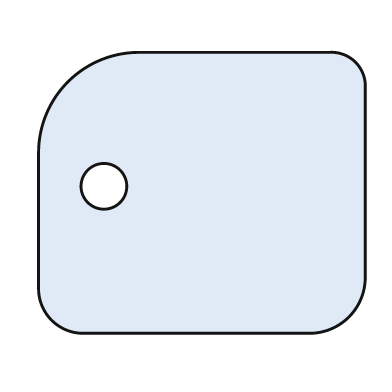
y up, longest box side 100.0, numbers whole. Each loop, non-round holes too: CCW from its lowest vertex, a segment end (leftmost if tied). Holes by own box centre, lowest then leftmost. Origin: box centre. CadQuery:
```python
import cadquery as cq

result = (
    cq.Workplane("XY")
    .moveTo(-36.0, -43.0)
    .lineTo(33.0, -43.0)
    .threePointArc((45.0, -38.0), (50.0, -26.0))
    .lineTo(50.0, 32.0)
    .threePointArc((47.0, 40.0), (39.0, 43.0))
    .lineTo(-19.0, 43.0)
    .threePointArc((-41.0, 34.0), (-50.0, 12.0))
    .lineTo(-50.0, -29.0)
    .threePointArc((-46.0, -39.0), (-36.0, -43.0))
    .close()
    .moveTo(-30.0, 2.0)
    .circle(7.0)
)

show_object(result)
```